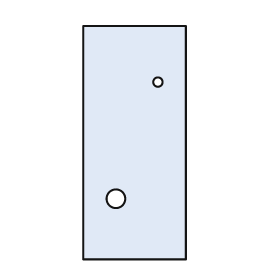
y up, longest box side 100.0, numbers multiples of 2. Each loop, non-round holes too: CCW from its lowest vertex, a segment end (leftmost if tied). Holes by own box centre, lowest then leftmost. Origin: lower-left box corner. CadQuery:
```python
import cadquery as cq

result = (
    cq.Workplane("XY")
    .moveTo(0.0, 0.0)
    .lineTo(44.0, 0.0)
    .lineTo(44.0, 100.0)
    .lineTo(0.0, 100.0)
    .close()
    .moveTo(14.0, 26.0)
    .circle(4.0)
    .moveTo(32.0, 76.0)
    .circle(2.0)
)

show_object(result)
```